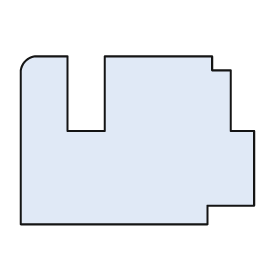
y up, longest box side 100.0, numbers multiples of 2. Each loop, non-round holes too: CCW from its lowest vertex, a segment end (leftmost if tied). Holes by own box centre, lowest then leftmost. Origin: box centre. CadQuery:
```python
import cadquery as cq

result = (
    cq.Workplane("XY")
    .moveTo(-50.0, -36.0)
    .lineTo(30.0, -36.0)
    .lineTo(30.0, -28.0)
    .lineTo(50.0, -28.0)
    .lineTo(50.0, 4.0)
    .lineTo(40.0, 4.0)
    .lineTo(40.0, 30.0)
    .lineTo(32.0, 30.0)
    .lineTo(32.0, 36.0)
    .lineTo(-14.0, 36.0)
    .lineTo(-14.0, 4.0)
    .lineTo(-30.0, 4.0)
    .lineTo(-30.0, 36.0)
    .lineTo(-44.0, 36.0)
    .threePointArc((-48.0, 34.0), (-50.0, 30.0))
    .close()
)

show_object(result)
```